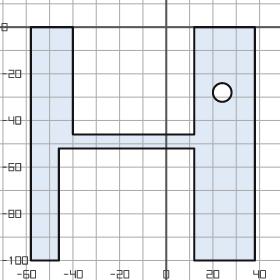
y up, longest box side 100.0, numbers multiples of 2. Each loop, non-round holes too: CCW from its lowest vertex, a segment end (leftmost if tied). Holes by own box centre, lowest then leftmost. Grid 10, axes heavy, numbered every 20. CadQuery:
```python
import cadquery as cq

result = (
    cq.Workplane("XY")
    .moveTo(-58.0, -100.0)
    .lineTo(-46.0, -100.0)
    .lineTo(-46.0, -52.0)
    .lineTo(12.0, -52.0)
    .lineTo(12.0, -100.0)
    .lineTo(38.0, -100.0)
    .lineTo(38.0, 0.0)
    .lineTo(12.0, 0.0)
    .lineTo(12.0, -46.0)
    .lineTo(-40.0, -46.0)
    .lineTo(-40.0, 0.0)
    .lineTo(-58.0, 0.0)
    .close()
    .moveTo(24.0, -28.0)
    .circle(4.0)
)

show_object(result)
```